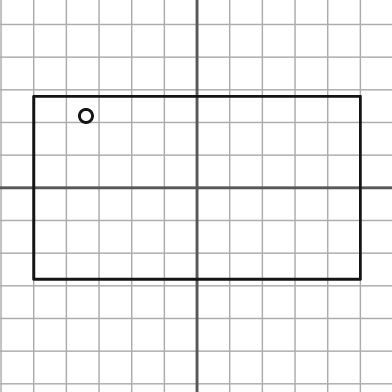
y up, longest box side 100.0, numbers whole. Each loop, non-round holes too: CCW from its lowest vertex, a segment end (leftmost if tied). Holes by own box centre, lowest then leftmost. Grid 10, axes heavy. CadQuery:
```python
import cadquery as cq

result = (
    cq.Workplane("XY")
    .moveTo(-50.0, -28.0)
    .lineTo(50.0, -28.0)
    .lineTo(50.0, 28.0)
    .lineTo(-50.0, 28.0)
    .close()
    .moveTo(-34.0, 22.0)
    .circle(2.0)
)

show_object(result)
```